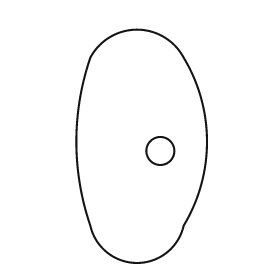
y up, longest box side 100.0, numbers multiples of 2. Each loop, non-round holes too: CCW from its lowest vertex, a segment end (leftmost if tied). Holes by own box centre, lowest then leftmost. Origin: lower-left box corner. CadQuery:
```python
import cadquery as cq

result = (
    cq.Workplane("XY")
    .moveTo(6.0, 16.0)
    .threePointArc((26.0, 0.0), (46.0, 16.0))
    .threePointArc((56.0, 52.0), (46.0, 88.0))
    .threePointArc((26.0, 100.0), (6.0, 88.0))
    .threePointArc((0.0, 52.0), (6.0, 16.0))
    .close()
    .moveTo(36.0, 48.0)
    .circle(6.0)
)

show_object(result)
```